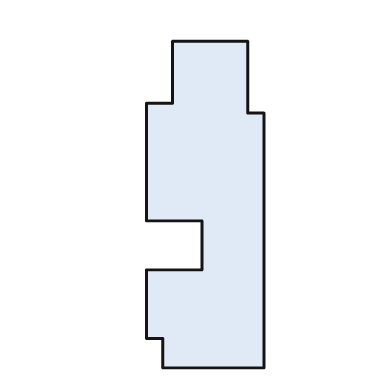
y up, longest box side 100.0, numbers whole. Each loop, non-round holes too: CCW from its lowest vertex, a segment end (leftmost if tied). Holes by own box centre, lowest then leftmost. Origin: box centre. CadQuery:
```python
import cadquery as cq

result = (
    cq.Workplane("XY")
    .moveTo(-13.0, -50.0)
    .lineTo(18.0, -50.0)
    .lineTo(18.0, 28.0)
    .lineTo(13.0, 28.0)
    .lineTo(13.0, 50.0)
    .lineTo(-10.0, 50.0)
    .lineTo(-10.0, 31.0)
    .lineTo(-18.0, 31.0)
    .lineTo(-18.0, -5.0)
    .lineTo(-1.0, -5.0)
    .lineTo(-1.0, -20.0)
    .lineTo(-18.0, -20.0)
    .lineTo(-18.0, -41.0)
    .lineTo(-13.0, -41.0)
    .close()
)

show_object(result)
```